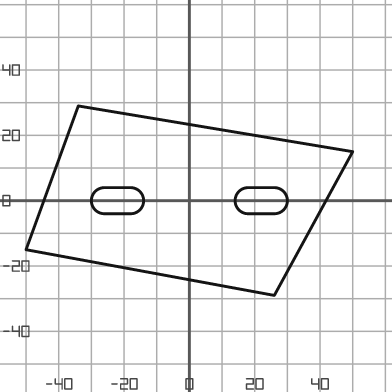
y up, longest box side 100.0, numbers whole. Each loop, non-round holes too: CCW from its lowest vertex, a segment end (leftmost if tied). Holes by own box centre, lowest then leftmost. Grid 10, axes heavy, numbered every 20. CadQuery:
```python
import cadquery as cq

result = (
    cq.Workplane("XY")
    .moveTo(26.0, -29.0)
    .lineTo(50.0, 15.0)
    .lineTo(-34.0, 29.0)
    .lineTo(-50.0, -15.0)
    .close()
    .moveTo(-26.0, -4.0)
    .lineTo(-18.0, -4.0)
    .threePointArc((-14.0, 0.0), (-18.0, 4.0))
    .lineTo(-26.0, 4.0)
    .threePointArc((-30.0, 0.0), (-26.0, -4.0))
    .close()
    .moveTo(18.0, -4.0)
    .lineTo(26.0, -4.0)
    .threePointArc((30.0, 0.0), (26.0, 4.0))
    .lineTo(18.0, 4.0)
    .threePointArc((14.0, 0.0), (18.0, -4.0))
    .close()
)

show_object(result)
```